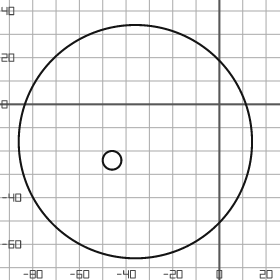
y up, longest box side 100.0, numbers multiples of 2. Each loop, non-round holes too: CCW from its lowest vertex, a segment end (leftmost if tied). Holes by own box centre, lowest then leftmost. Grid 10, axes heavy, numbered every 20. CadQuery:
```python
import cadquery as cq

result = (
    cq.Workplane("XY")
    .moveTo(-36.0, -16.0)
    .circle(50.0)
    .moveTo(-46.0, -24.0)
    .circle(4.0)
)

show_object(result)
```